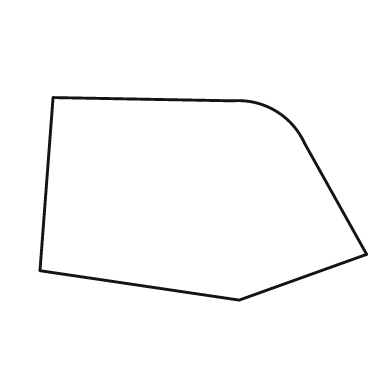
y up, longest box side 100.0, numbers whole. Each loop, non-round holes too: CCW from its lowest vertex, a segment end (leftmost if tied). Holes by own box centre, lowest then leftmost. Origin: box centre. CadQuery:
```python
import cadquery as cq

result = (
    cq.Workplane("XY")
    .moveTo(11.0, -31.0)
    .lineTo(50.0, -17.0)
    .lineTo(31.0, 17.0)
    .threePointArc((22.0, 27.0), (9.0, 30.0))
    .lineTo(-46.0, 31.0)
    .lineTo(-50.0, -22.0)
    .close()
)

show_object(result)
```